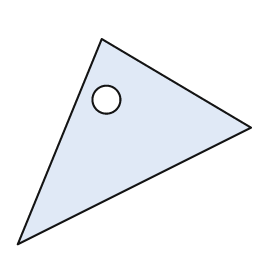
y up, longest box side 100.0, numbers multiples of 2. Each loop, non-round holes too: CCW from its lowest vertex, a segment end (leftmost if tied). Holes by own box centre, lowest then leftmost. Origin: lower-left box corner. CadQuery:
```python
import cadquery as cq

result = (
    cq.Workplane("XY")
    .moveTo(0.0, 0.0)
    .lineTo(100.0, 50.0)
    .lineTo(36.0, 88.0)
    .close()
    .moveTo(38.0, 62.0)
    .circle(6.0)
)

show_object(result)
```